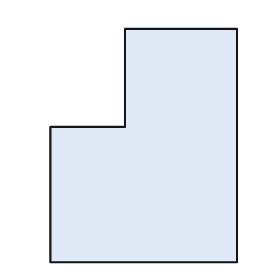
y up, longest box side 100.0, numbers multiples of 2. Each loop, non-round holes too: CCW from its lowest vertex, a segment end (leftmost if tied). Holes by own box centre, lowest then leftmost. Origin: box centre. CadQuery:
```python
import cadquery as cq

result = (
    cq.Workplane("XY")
    .moveTo(-40.0, -50.0)
    .lineTo(40.0, -50.0)
    .lineTo(40.0, 50.0)
    .lineTo(-8.0, 50.0)
    .lineTo(-8.0, 8.0)
    .lineTo(-40.0, 8.0)
    .close()
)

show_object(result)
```